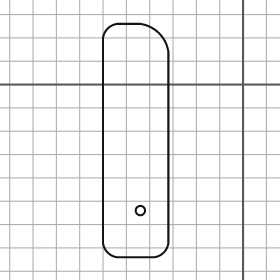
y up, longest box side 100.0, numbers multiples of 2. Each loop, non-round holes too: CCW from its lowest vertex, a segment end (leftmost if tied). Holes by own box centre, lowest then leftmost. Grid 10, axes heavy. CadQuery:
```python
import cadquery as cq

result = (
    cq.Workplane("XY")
    .moveTo(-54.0, -74.0)
    .lineTo(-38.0, -74.0)
    .threePointArc((-34.0, -72.0), (-32.0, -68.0))
    .lineTo(-32.0, 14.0)
    .threePointArc((-36.0, 22.0), (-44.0, 26.0))
    .lineTo(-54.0, 26.0)
    .threePointArc((-58.0, 24.0), (-60.0, 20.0))
    .lineTo(-60.0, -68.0)
    .threePointArc((-58.0, -72.0), (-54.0, -74.0))
    .close()
    .moveTo(-44.0, -54.0)
    .circle(2.0)
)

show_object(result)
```